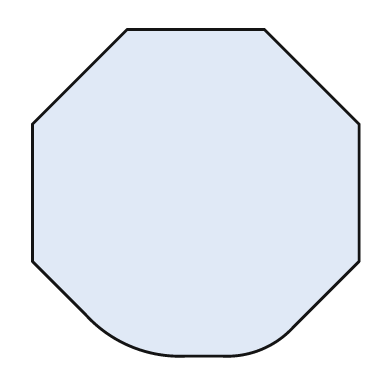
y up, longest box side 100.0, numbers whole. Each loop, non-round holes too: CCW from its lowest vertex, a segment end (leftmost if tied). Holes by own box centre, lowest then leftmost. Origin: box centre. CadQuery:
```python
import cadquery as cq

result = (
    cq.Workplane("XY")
    .moveTo(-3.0, -50.0)
    .lineTo(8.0, -50.0)
    .threePointArc((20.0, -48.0), (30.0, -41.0))
    .lineTo(50.0, -21.0)
    .lineTo(50.0, 21.0)
    .lineTo(21.0, 50.0)
    .lineTo(-21.0, 50.0)
    .lineTo(-50.0, 21.0)
    .lineTo(-50.0, -21.0)
    .lineTo(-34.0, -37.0)
    .threePointArc((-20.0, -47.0), (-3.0, -50.0))
    .close()
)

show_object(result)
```